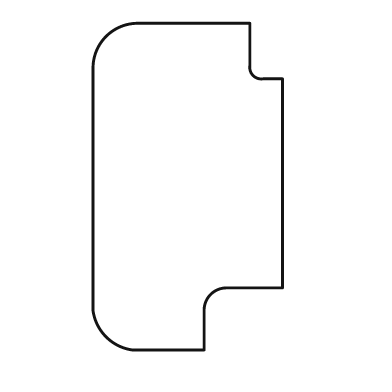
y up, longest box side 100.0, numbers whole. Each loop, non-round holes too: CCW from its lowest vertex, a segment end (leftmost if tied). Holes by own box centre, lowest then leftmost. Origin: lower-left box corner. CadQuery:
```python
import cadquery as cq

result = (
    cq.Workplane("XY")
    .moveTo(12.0, 0.0)
    .lineTo(34.0, 0.0)
    .lineTo(34.0, 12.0)
    .threePointArc((36.0, 17.0), (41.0, 19.0))
    .lineTo(58.0, 19.0)
    .lineTo(58.0, 83.0)
    .lineTo(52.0, 83.0)
    .threePointArc((49.0, 84.0), (48.0, 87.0))
    .lineTo(48.0, 100.0)
    .lineTo(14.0, 100.0)
    .threePointArc((4.0, 96.0), (0.0, 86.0))
    .lineTo(0.0, 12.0)
    .threePointArc((4.0, 4.0), (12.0, 0.0))
    .close()
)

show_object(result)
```